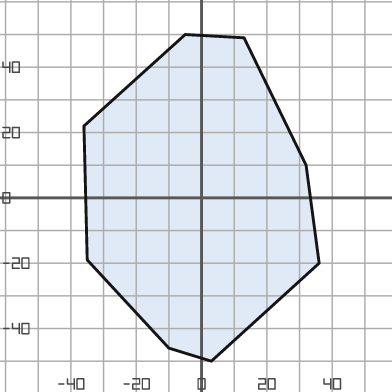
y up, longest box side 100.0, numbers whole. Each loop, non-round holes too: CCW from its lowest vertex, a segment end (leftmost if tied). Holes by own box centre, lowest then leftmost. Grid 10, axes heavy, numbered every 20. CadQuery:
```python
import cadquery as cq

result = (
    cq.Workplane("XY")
    .moveTo(3.0, -50.0)
    .lineTo(36.0, -20.0)
    .lineTo(32.0, 10.0)
    .lineTo(13.0, 49.0)
    .lineTo(-5.0, 50.0)
    .lineTo(-36.0, 22.0)
    .lineTo(-35.0, -19.0)
    .lineTo(-10.0, -46.0)
    .close()
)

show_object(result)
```